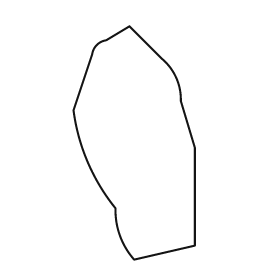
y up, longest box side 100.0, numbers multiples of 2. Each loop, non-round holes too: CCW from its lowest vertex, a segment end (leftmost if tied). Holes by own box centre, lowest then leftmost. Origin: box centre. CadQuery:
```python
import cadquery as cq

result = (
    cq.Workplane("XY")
    .moveTo(0.0, -50.0)
    .lineTo(26.0, -44.0)
    .lineTo(26.0, -2.0)
    .lineTo(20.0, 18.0)
    .threePointArc((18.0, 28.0), (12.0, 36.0))
    .lineTo(-2.0, 50.0)
    .lineTo(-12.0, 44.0)
    .threePointArc((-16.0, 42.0), (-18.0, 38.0))
    .lineTo(-26.0, 14.0)
    .threePointArc((-20.0, -8.0), (-8.0, -28.0))
    .threePointArc((-6.0, -40.0), (0.0, -50.0))
    .close()
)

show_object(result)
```